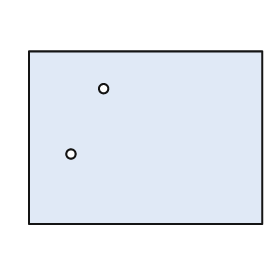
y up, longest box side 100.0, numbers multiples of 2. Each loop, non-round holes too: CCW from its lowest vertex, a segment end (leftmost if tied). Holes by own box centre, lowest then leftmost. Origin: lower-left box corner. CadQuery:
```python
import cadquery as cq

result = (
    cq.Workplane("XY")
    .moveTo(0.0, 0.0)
    .lineTo(100.0, 0.0)
    .lineTo(100.0, 74.0)
    .lineTo(0.0, 74.0)
    .close()
    .moveTo(18.0, 30.0)
    .circle(2.0)
    .moveTo(32.0, 58.0)
    .circle(2.0)
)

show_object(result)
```